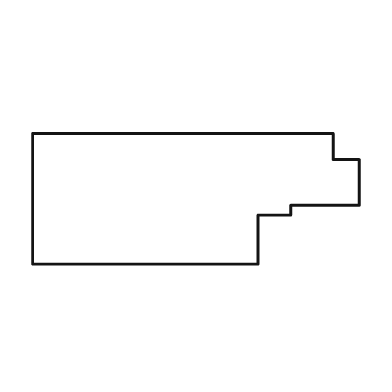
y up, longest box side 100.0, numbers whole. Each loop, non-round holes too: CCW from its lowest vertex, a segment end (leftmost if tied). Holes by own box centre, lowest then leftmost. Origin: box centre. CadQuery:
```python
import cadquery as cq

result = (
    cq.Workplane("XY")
    .moveTo(-50.0, -20.0)
    .lineTo(19.0, -20.0)
    .lineTo(19.0, -5.0)
    .lineTo(29.0, -5.0)
    .lineTo(29.0, -2.0)
    .lineTo(50.0, -2.0)
    .lineTo(50.0, 12.0)
    .lineTo(42.0, 12.0)
    .lineTo(42.0, 20.0)
    .lineTo(-50.0, 20.0)
    .close()
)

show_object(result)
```